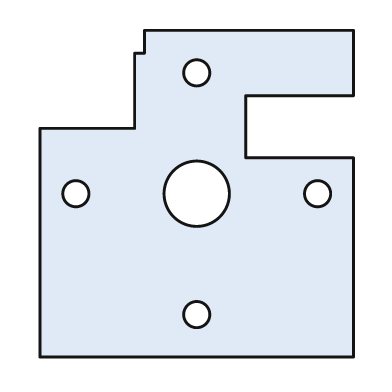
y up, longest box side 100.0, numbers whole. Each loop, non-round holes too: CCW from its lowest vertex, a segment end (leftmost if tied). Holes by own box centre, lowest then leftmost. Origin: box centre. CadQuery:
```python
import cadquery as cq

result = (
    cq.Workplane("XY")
    .moveTo(-48.0, -50.0)
    .lineTo(48.0, -50.0)
    .lineTo(48.0, 11.0)
    .lineTo(15.0, 11.0)
    .lineTo(15.0, 30.0)
    .lineTo(48.0, 30.0)
    .lineTo(48.0, 50.0)
    .lineTo(-16.0, 50.0)
    .lineTo(-16.0, 43.0)
    .lineTo(-19.0, 43.0)
    .lineTo(-19.0, 20.0)
    .lineTo(-48.0, 20.0)
    .close()
    .moveTo(0.0, -37.0)
    .circle(4.0)
    .moveTo(-37.0, 0.0)
    .circle(4.0)
    .moveTo(0.0, 0.0)
    .circle(10.0)
    .moveTo(37.0, 0.0)
    .circle(4.0)
    .moveTo(0.0, 37.0)
    .circle(4.0)
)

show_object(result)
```